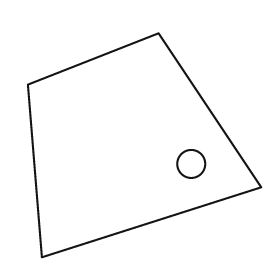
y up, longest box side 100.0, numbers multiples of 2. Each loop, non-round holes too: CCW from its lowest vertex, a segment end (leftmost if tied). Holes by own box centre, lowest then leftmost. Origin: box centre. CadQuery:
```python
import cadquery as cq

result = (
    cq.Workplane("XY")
    .moveTo(-44.0, -48.0)
    .lineTo(50.0, -18.0)
    .lineTo(6.0, 48.0)
    .lineTo(-50.0, 26.0)
    .close()
    .moveTo(20.0, -8.0)
    .circle(6.0)
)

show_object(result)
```